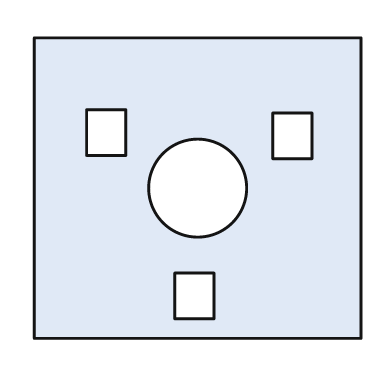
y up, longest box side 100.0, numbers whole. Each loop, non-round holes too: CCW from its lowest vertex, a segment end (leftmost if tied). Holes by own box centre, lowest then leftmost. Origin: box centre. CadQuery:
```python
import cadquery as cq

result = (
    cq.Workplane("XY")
    .moveTo(-50.0, -46.0)
    .lineTo(50.0, -46.0)
    .lineTo(50.0, 46.0)
    .lineTo(-50.0, 46.0)
    .close()
    .moveTo(-7.0, -40.0)
    .lineTo(5.0, -40.0)
    .lineTo(5.0, -26.0)
    .lineTo(-7.0, -26.0)
    .close()
    .moveTo(0.0, 0.0)
    .circle(15.0)
    .moveTo(23.0, 9.0)
    .lineTo(35.0, 9.0)
    .lineTo(35.0, 23.0)
    .lineTo(23.0, 23.0)
    .close()
    .moveTo(-34.0, 10.0)
    .lineTo(-22.0, 10.0)
    .lineTo(-22.0, 24.0)
    .lineTo(-34.0, 24.0)
    .close()
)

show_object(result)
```